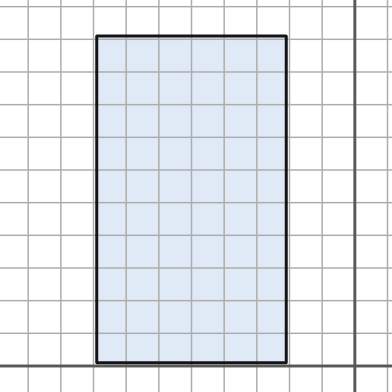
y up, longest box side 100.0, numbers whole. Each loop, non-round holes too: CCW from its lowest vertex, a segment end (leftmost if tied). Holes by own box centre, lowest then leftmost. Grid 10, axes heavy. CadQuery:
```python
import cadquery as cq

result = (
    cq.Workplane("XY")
    .moveTo(-79.0, 1.0)
    .lineTo(-21.0, 1.0)
    .lineTo(-21.0, 101.0)
    .lineTo(-79.0, 101.0)
    .close()
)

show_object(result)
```